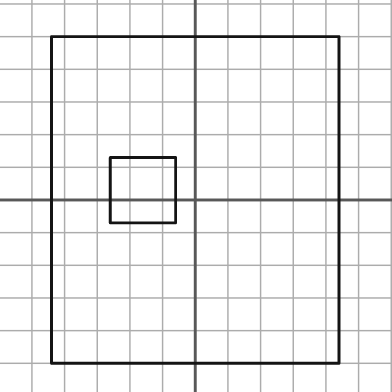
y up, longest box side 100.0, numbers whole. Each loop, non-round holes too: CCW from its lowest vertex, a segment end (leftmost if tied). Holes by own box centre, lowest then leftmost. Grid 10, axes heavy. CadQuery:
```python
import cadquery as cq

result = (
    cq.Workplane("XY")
    .moveTo(-44.0, -50.0)
    .lineTo(44.0, -50.0)
    .lineTo(44.0, 50.0)
    .lineTo(-44.0, 50.0)
    .close()
    .moveTo(-26.0, -7.0)
    .lineTo(-6.0, -7.0)
    .lineTo(-6.0, 13.0)
    .lineTo(-26.0, 13.0)
    .close()
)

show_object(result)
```